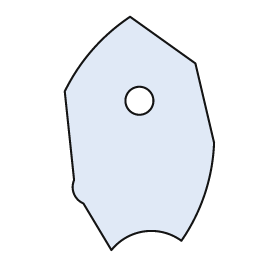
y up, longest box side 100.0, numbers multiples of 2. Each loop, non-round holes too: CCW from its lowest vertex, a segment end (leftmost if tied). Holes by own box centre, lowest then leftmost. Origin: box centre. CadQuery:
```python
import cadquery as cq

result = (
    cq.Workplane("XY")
    .moveTo(-12.0, -50.0)
    .threePointArc((2.0, -42.0), (18.0, -46.0))
    .threePointArc((28.0, -26.0), (32.0, -4.0))
    .lineTo(24.0, 30.0)
    .lineTo(-4.0, 50.0)
    .threePointArc((-20.0, 36.0), (-32.0, 18.0))
    .lineTo(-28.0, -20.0)
    .threePointArc((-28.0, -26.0), (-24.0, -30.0))
    .close()
    .moveTo(0.0, 14.0)
    .circle(6.0)
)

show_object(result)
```